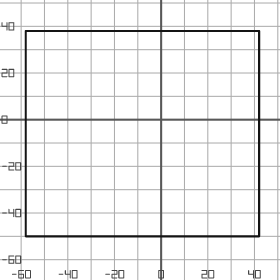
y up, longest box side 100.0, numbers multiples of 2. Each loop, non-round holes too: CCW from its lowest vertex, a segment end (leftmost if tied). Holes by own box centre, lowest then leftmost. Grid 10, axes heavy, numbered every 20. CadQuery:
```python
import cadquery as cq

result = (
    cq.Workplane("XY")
    .moveTo(-58.0, -50.0)
    .lineTo(42.0, -50.0)
    .lineTo(42.0, 38.0)
    .lineTo(-58.0, 38.0)
    .close()
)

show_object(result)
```